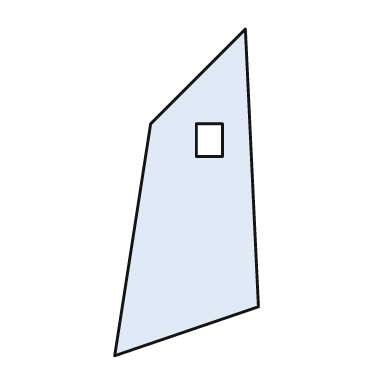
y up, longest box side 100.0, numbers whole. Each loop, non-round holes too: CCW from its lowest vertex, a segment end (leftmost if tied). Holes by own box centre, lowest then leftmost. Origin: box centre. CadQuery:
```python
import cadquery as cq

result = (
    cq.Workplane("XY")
    .moveTo(-22.0, -50.0)
    .lineTo(22.0, -35.0)
    .lineTo(18.0, 50.0)
    .lineTo(-11.0, 21.0)
    .close()
    .moveTo(3.0, 11.0)
    .lineTo(11.0, 11.0)
    .lineTo(11.0, 21.0)
    .lineTo(3.0, 21.0)
    .close()
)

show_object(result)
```